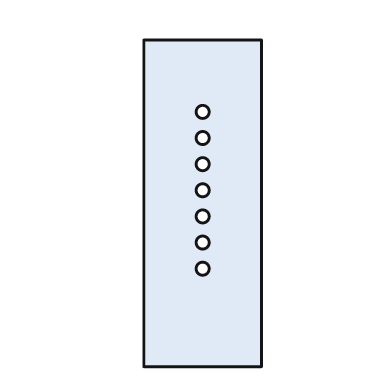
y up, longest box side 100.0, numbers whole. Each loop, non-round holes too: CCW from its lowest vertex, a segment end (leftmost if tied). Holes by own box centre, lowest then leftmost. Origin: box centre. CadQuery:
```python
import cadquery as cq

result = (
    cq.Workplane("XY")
    .moveTo(-18.0, -50.0)
    .lineTo(18.0, -50.0)
    .lineTo(18.0, 50.0)
    .lineTo(-18.0, 50.0)
    .close()
    .moveTo(0.0, -20.0)
    .circle(2.0)
    .moveTo(0.0, -12.0)
    .circle(2.0)
    .moveTo(0.0, -4.0)
    .circle(2.0)
    .moveTo(0.0, 4.0)
    .circle(2.0)
    .moveTo(0.0, 12.0)
    .circle(2.0)
    .moveTo(0.0, 20.0)
    .circle(2.0)
    .moveTo(0.0, 28.0)
    .circle(2.0)
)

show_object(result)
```